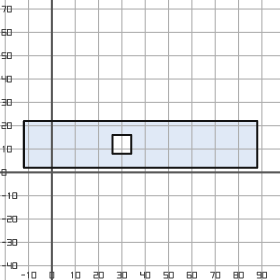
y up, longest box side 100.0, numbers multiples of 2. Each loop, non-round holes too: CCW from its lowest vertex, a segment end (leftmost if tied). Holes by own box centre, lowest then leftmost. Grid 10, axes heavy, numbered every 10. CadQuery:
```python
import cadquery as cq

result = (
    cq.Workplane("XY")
    .moveTo(-12.0, 2.0)
    .lineTo(88.0, 2.0)
    .lineTo(88.0, 22.0)
    .lineTo(-12.0, 22.0)
    .close()
    .moveTo(26.0, 8.0)
    .lineTo(34.0, 8.0)
    .lineTo(34.0, 16.0)
    .lineTo(26.0, 16.0)
    .close()
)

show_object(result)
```